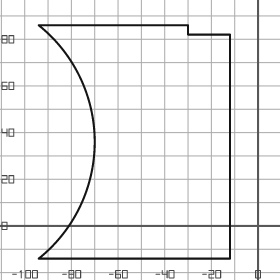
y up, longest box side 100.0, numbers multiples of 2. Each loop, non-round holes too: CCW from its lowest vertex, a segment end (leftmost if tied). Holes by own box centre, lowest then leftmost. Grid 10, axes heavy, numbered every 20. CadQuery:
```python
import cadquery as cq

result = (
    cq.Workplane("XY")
    .moveTo(-94.0, -14.0)
    .lineTo(-12.0, -14.0)
    .lineTo(-12.0, 82.0)
    .lineTo(-30.0, 82.0)
    .lineTo(-30.0, 86.0)
    .lineTo(-94.0, 86.0)
    .threePointArc((-70.0, 36.0), (-94.0, -14.0))
    .close()
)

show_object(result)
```